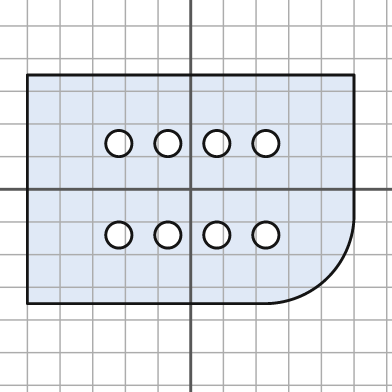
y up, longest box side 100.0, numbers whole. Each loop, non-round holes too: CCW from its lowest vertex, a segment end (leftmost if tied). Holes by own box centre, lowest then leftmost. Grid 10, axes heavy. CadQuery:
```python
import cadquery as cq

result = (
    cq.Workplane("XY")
    .moveTo(-50.0, -35.0)
    .lineTo(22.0, -35.0)
    .threePointArc((42.0, -27.0), (50.0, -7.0))
    .lineTo(50.0, 35.0)
    .lineTo(-50.0, 35.0)
    .close()
    .moveTo(-22.0, -14.0)
    .circle(4.0)
    .moveTo(-7.0, -14.0)
    .circle(4.0)
    .moveTo(8.0, -14.0)
    .circle(4.0)
    .moveTo(23.0, -14.0)
    .circle(4.0)
    .moveTo(-22.0, 14.0)
    .circle(4.0)
    .moveTo(-7.0, 14.0)
    .circle(4.0)
    .moveTo(8.0, 14.0)
    .circle(4.0)
    .moveTo(23.0, 14.0)
    .circle(4.0)
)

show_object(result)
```